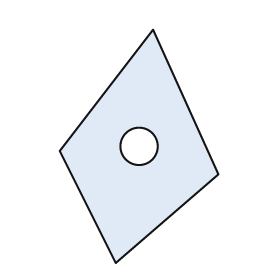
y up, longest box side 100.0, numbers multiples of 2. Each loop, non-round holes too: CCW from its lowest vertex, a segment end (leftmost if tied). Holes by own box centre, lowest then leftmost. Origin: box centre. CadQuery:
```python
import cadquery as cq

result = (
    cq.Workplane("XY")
    .moveTo(-10.0, -50.0)
    .lineTo(34.0, -12.0)
    .lineTo(6.0, 50.0)
    .lineTo(-34.0, -2.0)
    .close()
    .moveTo(0.0, 0.0)
    .circle(8.0)
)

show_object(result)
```